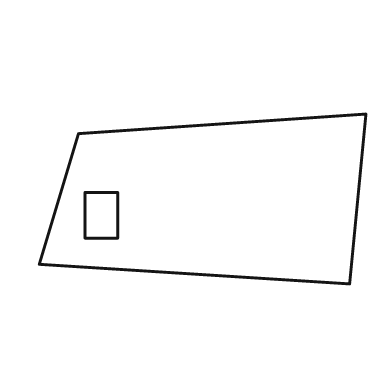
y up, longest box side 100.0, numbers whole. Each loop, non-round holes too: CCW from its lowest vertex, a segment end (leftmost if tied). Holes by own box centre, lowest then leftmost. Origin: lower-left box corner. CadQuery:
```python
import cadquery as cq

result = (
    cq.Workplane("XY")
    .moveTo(95.0, 0.0)
    .lineTo(100.0, 52.0)
    .lineTo(12.0, 46.0)
    .lineTo(0.0, 6.0)
    .close()
    .moveTo(14.0, 14.0)
    .lineTo(24.0, 14.0)
    .lineTo(24.0, 28.0)
    .lineTo(14.0, 28.0)
    .close()
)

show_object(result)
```